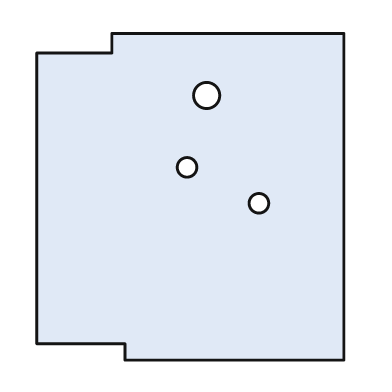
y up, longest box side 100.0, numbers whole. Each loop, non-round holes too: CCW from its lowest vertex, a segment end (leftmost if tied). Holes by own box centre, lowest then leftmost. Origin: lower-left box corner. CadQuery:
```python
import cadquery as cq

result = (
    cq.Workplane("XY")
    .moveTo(27.0, 0.0)
    .lineTo(94.0, 0.0)
    .lineTo(94.0, 100.0)
    .lineTo(23.0, 100.0)
    .lineTo(23.0, 94.0)
    .lineTo(0.0, 94.0)
    .lineTo(0.0, 5.0)
    .lineTo(27.0, 5.0)
    .close()
    .moveTo(68.0, 48.0)
    .circle(3.0)
    .moveTo(46.0, 59.0)
    .circle(3.0)
    .moveTo(52.0, 81.0)
    .circle(4.0)
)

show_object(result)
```